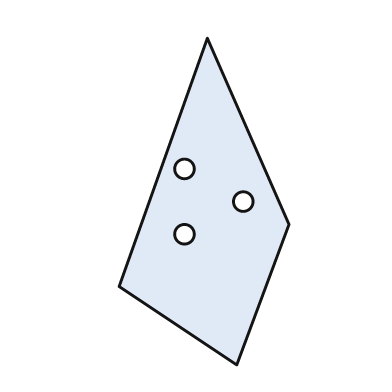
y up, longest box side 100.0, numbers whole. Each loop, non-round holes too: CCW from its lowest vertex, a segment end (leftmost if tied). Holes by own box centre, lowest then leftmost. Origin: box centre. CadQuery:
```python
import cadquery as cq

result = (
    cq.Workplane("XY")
    .moveTo(10.0, -50.0)
    .lineTo(26.0, -7.0)
    .lineTo(1.0, 50.0)
    .lineTo(-26.0, -26.0)
    .close()
    .moveTo(-6.0, -10.0)
    .circle(3.0)
    .moveTo(12.0, 0.0)
    .circle(3.0)
    .moveTo(-6.0, 10.0)
    .circle(3.0)
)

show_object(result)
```